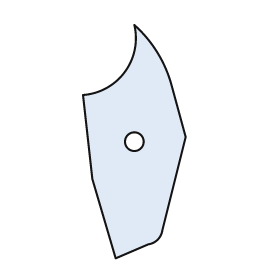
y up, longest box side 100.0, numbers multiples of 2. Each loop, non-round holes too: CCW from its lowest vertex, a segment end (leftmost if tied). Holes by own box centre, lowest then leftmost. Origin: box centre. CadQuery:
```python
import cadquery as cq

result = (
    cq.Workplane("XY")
    .moveTo(-8.0, -50.0)
    .lineTo(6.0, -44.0)
    .threePointArc((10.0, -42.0), (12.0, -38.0))
    .lineTo(22.0, 2.0)
    .lineTo(16.0, 24.0)
    .threePointArc((10.0, 38.0), (0.0, 50.0))
    .threePointArc((-4.0, 30.0), (-22.0, 20.0))
    .lineTo(-18.0, -16.0)
    .close()
    .moveTo(0.0, 0.0)
    .circle(4.0)
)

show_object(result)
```